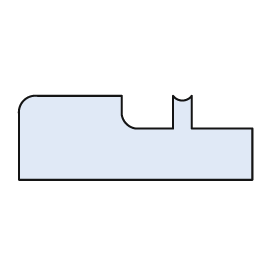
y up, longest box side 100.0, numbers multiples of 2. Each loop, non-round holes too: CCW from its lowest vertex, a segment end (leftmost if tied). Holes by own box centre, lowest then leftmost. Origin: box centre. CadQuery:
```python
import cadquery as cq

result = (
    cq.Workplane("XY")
    .moveTo(-50.0, -18.0)
    .lineTo(50.0, -18.0)
    .lineTo(50.0, 4.0)
    .lineTo(24.0, 4.0)
    .lineTo(24.0, 18.0)
    .threePointArc((20.0, 16.0), (16.0, 18.0))
    .lineTo(16.0, 4.0)
    .lineTo(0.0, 4.0)
    .threePointArc((-4.0, 6.0), (-6.0, 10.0))
    .lineTo(-6.0, 18.0)
    .lineTo(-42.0, 18.0)
    .threePointArc((-48.0, 16.0), (-50.0, 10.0))
    .close()
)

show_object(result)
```